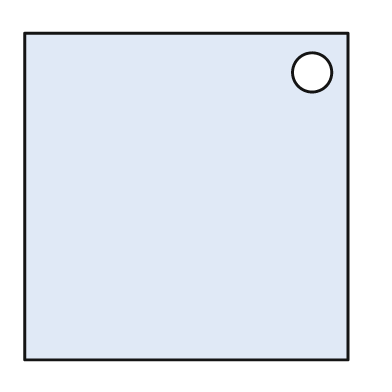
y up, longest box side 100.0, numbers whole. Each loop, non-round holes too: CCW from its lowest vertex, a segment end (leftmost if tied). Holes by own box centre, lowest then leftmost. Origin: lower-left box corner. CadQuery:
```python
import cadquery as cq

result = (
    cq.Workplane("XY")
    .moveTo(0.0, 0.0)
    .lineTo(99.0, 0.0)
    .lineTo(99.0, 100.0)
    .lineTo(0.0, 100.0)
    .close()
    .moveTo(88.0, 88.0)
    .circle(6.0)
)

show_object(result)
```